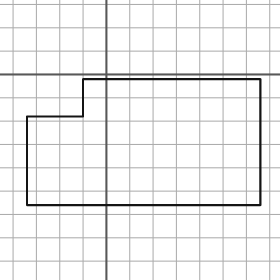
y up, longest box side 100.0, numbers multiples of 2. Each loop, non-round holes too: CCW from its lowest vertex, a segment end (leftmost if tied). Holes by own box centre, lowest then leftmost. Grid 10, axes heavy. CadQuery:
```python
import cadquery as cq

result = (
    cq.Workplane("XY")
    .moveTo(-34.0, -56.0)
    .lineTo(66.0, -56.0)
    .lineTo(66.0, -2.0)
    .lineTo(-10.0, -2.0)
    .lineTo(-10.0, -18.0)
    .lineTo(-34.0, -18.0)
    .close()
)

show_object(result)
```